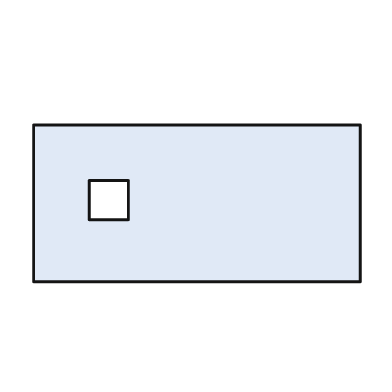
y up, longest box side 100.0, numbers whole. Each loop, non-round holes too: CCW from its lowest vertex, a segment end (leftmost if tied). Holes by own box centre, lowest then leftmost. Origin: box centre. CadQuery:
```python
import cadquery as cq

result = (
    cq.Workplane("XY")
    .moveTo(-50.0, -24.0)
    .lineTo(50.0, -24.0)
    .lineTo(50.0, 24.0)
    .lineTo(-50.0, 24.0)
    .close()
    .moveTo(-33.0, -5.0)
    .lineTo(-21.0, -5.0)
    .lineTo(-21.0, 7.0)
    .lineTo(-33.0, 7.0)
    .close()
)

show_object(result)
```